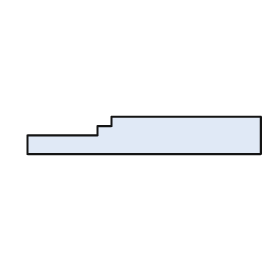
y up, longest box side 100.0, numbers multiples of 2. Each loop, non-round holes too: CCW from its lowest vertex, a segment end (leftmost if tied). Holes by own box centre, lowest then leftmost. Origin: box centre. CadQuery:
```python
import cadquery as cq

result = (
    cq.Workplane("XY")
    .moveTo(-50.0, -8.0)
    .lineTo(50.0, -8.0)
    .lineTo(50.0, 8.0)
    .lineTo(-14.0, 8.0)
    .lineTo(-14.0, 4.0)
    .lineTo(-20.0, 4.0)
    .lineTo(-20.0, 0.0)
    .lineTo(-50.0, 0.0)
    .close()
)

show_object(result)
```